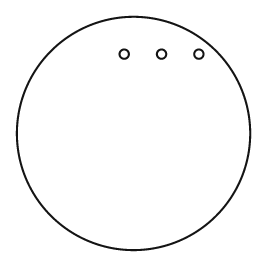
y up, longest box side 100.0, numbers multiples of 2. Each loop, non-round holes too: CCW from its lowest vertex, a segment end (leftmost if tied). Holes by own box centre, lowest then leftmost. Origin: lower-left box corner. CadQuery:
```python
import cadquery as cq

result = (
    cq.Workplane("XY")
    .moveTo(50.0, 50.0)
    .circle(50.0)
    .moveTo(46.0, 84.0)
    .circle(2.0)
    .moveTo(62.0, 84.0)
    .circle(2.0)
    .moveTo(78.0, 84.0)
    .circle(2.0)
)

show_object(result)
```